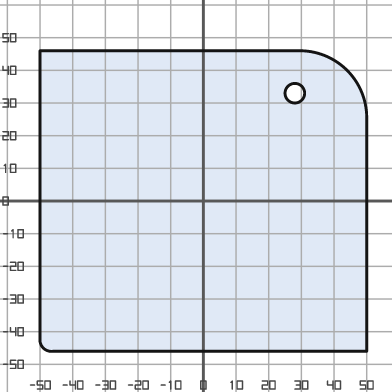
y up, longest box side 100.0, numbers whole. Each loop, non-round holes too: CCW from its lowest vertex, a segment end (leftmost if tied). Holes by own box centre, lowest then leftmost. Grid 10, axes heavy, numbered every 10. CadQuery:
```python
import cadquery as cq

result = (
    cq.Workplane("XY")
    .moveTo(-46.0, -46.0)
    .lineTo(50.0, -46.0)
    .lineTo(50.0, 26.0)
    .threePointArc((44.0, 40.0), (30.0, 46.0))
    .lineTo(-50.0, 46.0)
    .lineTo(-50.0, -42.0)
    .threePointArc((-49.0, -45.0), (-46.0, -46.0))
    .close()
    .moveTo(28.0, 33.0)
    .circle(3.0)
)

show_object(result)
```